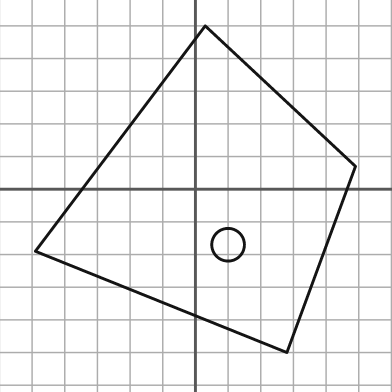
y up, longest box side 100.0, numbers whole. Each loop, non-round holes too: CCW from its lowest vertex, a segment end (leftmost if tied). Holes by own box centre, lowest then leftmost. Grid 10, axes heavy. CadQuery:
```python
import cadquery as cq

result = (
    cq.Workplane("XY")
    .moveTo(28.0, -50.0)
    .lineTo(49.0, 7.0)
    .lineTo(3.0, 50.0)
    .lineTo(-49.0, -19.0)
    .close()
    .moveTo(10.0, -17.0)
    .circle(5.0)
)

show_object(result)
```